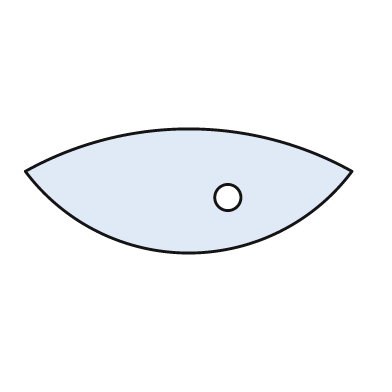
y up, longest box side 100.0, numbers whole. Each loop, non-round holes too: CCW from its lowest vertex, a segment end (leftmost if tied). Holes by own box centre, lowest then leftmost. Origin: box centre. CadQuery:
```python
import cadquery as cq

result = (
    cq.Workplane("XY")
    .moveTo(-50.0, 6.0)
    .threePointArc((0.0, -19.0), (50.0, 6.0))
    .threePointArc((0.0, 19.0), (-50.0, 6.0))
    .close()
    .moveTo(12.0, -2.0)
    .circle(4.0)
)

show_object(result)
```